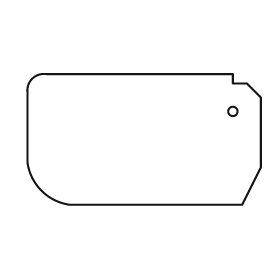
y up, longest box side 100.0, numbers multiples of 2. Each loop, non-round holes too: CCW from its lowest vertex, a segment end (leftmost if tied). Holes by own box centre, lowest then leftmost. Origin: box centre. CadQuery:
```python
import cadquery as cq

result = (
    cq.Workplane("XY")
    .moveTo(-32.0, -28.0)
    .lineTo(42.0, -28.0)
    .lineTo(50.0, -12.0)
    .lineTo(50.0, 18.0)
    .lineTo(44.0, 24.0)
    .lineTo(38.0, 24.0)
    .lineTo(38.0, 28.0)
    .lineTo(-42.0, 28.0)
    .threePointArc((-48.0, 26.0), (-50.0, 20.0))
    .lineTo(-50.0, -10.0)
    .threePointArc((-44.0, -22.0), (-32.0, -28.0))
    .close()
    .moveTo(38.0, 12.0)
    .circle(2.0)
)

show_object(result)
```